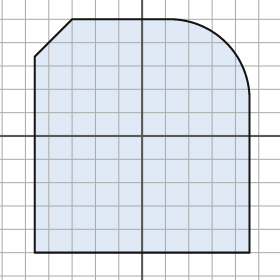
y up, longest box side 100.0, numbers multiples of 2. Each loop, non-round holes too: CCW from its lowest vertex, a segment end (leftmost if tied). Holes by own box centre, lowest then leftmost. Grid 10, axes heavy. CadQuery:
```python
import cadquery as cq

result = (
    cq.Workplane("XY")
    .moveTo(-46.0, -50.0)
    .lineTo(46.0, -50.0)
    .lineTo(46.0, 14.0)
    .threePointArc((36.0, 40.0), (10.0, 50.0))
    .lineTo(-30.0, 50.0)
    .lineTo(-46.0, 34.0)
    .close()
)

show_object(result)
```